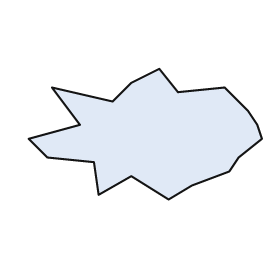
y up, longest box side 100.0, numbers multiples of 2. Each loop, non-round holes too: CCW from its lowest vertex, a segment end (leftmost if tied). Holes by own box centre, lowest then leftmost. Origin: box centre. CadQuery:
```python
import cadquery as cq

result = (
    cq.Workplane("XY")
    .moveTo(10.0, -28.0)
    .lineTo(20.0, -22.0)
    .lineTo(36.0, -16.0)
    .lineTo(40.0, -10.0)
    .lineTo(50.0, -2.0)
    .lineTo(48.0, 4.0)
    .lineTo(44.0, 10.0)
    .lineTo(34.0, 20.0)
    .lineTo(14.0, 18.0)
    .lineTo(6.0, 28.0)
    .lineTo(-6.0, 22.0)
    .lineTo(-14.0, 14.0)
    .lineTo(-40.0, 20.0)
    .lineTo(-28.0, 4.0)
    .lineTo(-50.0, -2.0)
    .lineTo(-42.0, -10.0)
    .lineTo(-22.0, -12.0)
    .lineTo(-20.0, -26.0)
    .lineTo(-6.0, -18.0)
    .close()
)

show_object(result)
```